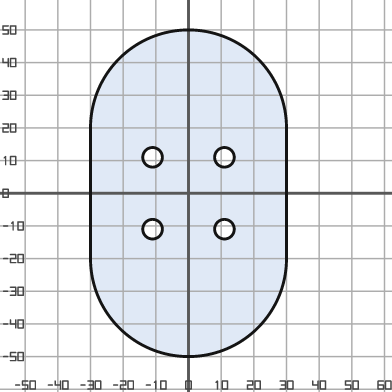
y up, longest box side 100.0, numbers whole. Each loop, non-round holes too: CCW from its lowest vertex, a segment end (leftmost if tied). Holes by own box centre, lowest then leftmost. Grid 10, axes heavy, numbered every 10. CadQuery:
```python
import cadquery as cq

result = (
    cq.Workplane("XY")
    .moveTo(-30.0, -20.0)
    .threePointArc((0.0, -50.0), (30.0, -20.0))
    .lineTo(30.0, 20.0)
    .threePointArc((0.0, 50.0), (-30.0, 20.0))
    .close()
    .moveTo(-11.0, -11.0)
    .circle(3.0)
    .moveTo(11.0, -11.0)
    .circle(3.0)
    .moveTo(-11.0, 11.0)
    .circle(3.0)
    .moveTo(11.0, 11.0)
    .circle(3.0)
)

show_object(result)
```